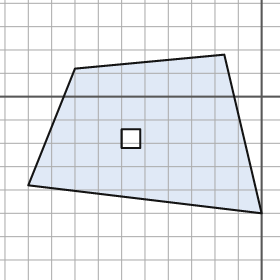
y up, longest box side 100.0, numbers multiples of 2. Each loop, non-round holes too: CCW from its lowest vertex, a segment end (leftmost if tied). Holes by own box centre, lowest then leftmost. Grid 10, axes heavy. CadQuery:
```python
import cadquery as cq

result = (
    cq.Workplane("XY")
    .moveTo(0.0, -50.0)
    .lineTo(-16.0, 18.0)
    .lineTo(-80.0, 12.0)
    .lineTo(-100.0, -38.0)
    .close()
    .moveTo(-60.0, -22.0)
    .lineTo(-52.0, -22.0)
    .lineTo(-52.0, -14.0)
    .lineTo(-60.0, -14.0)
    .close()
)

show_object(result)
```